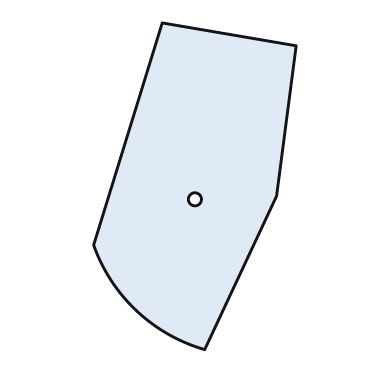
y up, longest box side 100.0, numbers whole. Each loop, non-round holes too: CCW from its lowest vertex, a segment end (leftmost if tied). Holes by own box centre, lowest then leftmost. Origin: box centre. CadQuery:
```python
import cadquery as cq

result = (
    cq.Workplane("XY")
    .moveTo(3.0, -50.0)
    .lineTo(25.0, -3.0)
    .lineTo(31.0, 43.0)
    .lineTo(-10.0, 50.0)
    .lineTo(-31.0, -18.0)
    .threePointArc((-18.0, -38.0), (3.0, -50.0))
    .close()
    .moveTo(0.0, -4.0)
    .circle(2.0)
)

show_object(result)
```